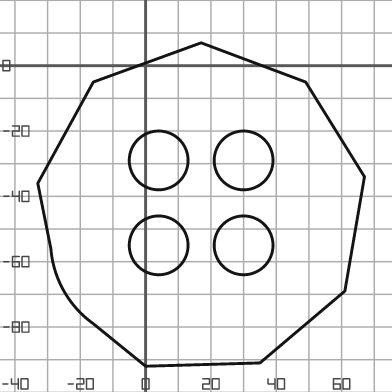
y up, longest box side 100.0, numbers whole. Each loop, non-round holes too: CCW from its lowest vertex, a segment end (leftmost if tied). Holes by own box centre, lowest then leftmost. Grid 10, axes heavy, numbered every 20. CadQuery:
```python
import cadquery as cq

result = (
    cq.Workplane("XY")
    .moveTo(0.0, -92.0)
    .lineTo(35.0, -91.0)
    .lineTo(61.0, -69.0)
    .lineTo(67.0, -34.0)
    .lineTo(49.0, -5.0)
    .lineTo(17.0, 7.0)
    .lineTo(-16.0, -5.0)
    .lineTo(-33.0, -36.0)
    .lineTo(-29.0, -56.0)
    .threePointArc((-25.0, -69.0), (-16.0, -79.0))
    .close()
    .moveTo(4.0, -55.0)
    .circle(9.0)
    .moveTo(30.0, -55.0)
    .circle(9.0)
    .moveTo(4.0, -29.0)
    .circle(9.0)
    .moveTo(30.0, -29.0)
    .circle(9.0)
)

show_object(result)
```